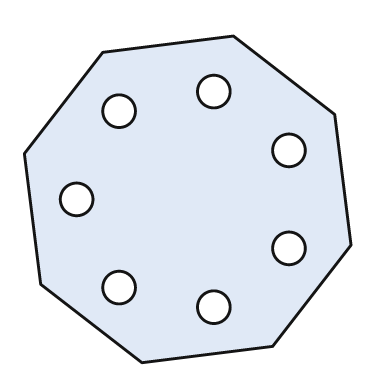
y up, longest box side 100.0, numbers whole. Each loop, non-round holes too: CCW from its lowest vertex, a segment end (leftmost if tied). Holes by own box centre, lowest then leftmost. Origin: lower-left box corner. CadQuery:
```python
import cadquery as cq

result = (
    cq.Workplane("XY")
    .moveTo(36.0, 0.0)
    .lineTo(76.0, 5.0)
    .lineTo(100.0, 36.0)
    .lineTo(95.0, 76.0)
    .lineTo(64.0, 100.0)
    .lineTo(24.0, 95.0)
    .lineTo(0.0, 64.0)
    .lineTo(5.0, 24.0)
    .close()
    .moveTo(58.0, 17.0)
    .circle(5.0)
    .moveTo(29.0, 23.0)
    .circle(5.0)
    .moveTo(81.0, 35.0)
    .circle(5.0)
    .moveTo(16.0, 50.0)
    .circle(5.0)
    .moveTo(81.0, 65.0)
    .circle(5.0)
    .moveTo(29.0, 77.0)
    .circle(5.0)
    .moveTo(58.0, 83.0)
    .circle(5.0)
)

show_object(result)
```